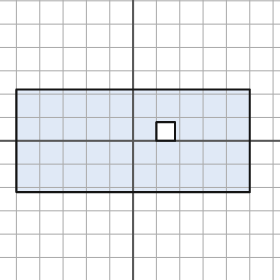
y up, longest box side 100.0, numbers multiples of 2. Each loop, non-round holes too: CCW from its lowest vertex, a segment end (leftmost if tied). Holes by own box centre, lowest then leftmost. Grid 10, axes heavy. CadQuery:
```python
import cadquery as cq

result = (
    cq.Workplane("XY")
    .moveTo(-50.0, -22.0)
    .lineTo(50.0, -22.0)
    .lineTo(50.0, 22.0)
    .lineTo(-50.0, 22.0)
    .close()
    .moveTo(10.0, 0.0)
    .lineTo(18.0, 0.0)
    .lineTo(18.0, 8.0)
    .lineTo(10.0, 8.0)
    .close()
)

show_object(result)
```